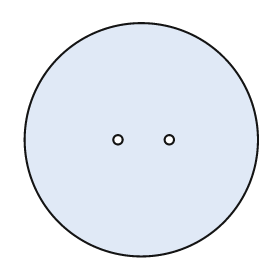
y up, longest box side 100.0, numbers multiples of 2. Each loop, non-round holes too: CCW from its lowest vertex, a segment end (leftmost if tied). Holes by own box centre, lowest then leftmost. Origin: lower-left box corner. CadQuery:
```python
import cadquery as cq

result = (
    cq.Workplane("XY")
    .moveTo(50.0, 50.0)
    .circle(50.0)
    .moveTo(40.0, 50.0)
    .circle(2.0)
    .moveTo(62.0, 50.0)
    .circle(2.0)
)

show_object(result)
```